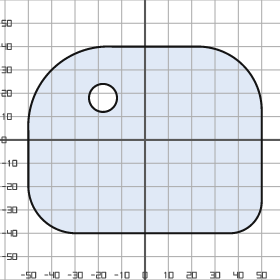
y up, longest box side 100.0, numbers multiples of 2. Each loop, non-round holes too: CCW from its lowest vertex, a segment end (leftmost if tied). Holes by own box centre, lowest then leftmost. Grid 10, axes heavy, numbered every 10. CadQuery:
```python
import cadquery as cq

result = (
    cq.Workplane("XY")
    .moveTo(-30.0, -40.0)
    .lineTo(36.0, -40.0)
    .threePointArc((46.0, -36.0), (50.0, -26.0))
    .lineTo(50.0, 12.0)
    .threePointArc((42.0, 32.0), (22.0, 40.0))
    .lineTo(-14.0, 40.0)
    .threePointArc((-40.0, 30.0), (-50.0, 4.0))
    .lineTo(-50.0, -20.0)
    .threePointArc((-44.0, -34.0), (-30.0, -40.0))
    .close()
    .moveTo(-18.0, 18.0)
    .circle(6.0)
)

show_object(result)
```